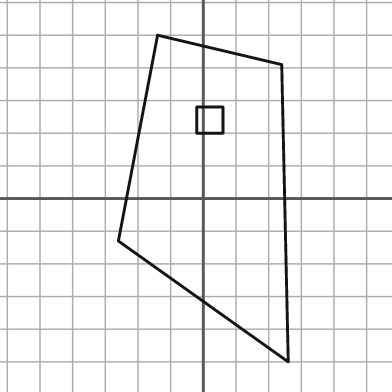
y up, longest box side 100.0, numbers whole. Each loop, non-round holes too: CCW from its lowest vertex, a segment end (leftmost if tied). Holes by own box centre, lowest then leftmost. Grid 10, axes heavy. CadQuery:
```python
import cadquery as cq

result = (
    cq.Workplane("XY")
    .moveTo(26.0, -50.0)
    .lineTo(24.0, 41.0)
    .lineTo(-14.0, 50.0)
    .lineTo(-26.0, -13.0)
    .close()
    .moveTo(-2.0, 20.0)
    .lineTo(6.0, 20.0)
    .lineTo(6.0, 28.0)
    .lineTo(-2.0, 28.0)
    .close()
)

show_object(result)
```